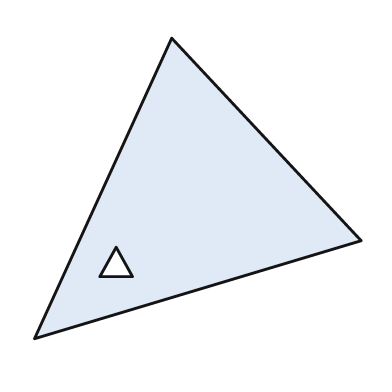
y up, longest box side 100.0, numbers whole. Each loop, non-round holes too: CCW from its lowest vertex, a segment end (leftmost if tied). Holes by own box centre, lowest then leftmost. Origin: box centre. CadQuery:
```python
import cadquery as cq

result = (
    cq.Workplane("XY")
    .moveTo(-50.0, -46.0)
    .lineTo(50.0, -16.0)
    .lineTo(-8.0, 46.0)
    .close()
    .moveTo(-30.0, -27.0)
    .lineTo(-20.0, -27.0)
    .lineTo(-25.0, -18.0)
    .close()
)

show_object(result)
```